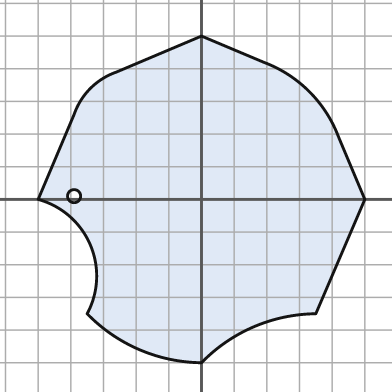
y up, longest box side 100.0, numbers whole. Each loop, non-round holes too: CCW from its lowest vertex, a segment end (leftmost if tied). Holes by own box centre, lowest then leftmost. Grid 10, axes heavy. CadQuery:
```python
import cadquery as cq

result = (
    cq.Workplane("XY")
    .moveTo(0.0, -50.0)
    .threePointArc((16.0, -39.0), (35.0, -35.0))
    .lineTo(50.0, 0.0)
    .lineTo(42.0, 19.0)
    .threePointArc((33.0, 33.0), (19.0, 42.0))
    .lineTo(0.0, 50.0)
    .lineTo(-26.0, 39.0)
    .threePointArc((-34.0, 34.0), (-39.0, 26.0))
    .lineTo(-50.0, 0.0)
    .threePointArc((-34.0, -14.0), (-35.0, -35.0))
    .threePointArc((-19.0, -46.0), (0.0, -50.0))
    .close()
    .moveTo(-39.0, 1.0)
    .circle(2.0)
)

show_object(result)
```